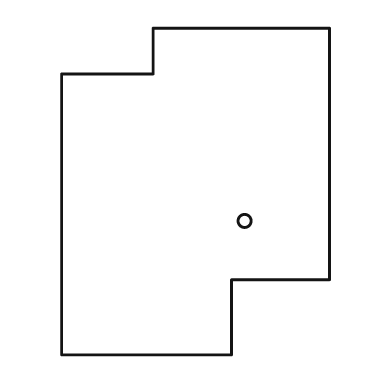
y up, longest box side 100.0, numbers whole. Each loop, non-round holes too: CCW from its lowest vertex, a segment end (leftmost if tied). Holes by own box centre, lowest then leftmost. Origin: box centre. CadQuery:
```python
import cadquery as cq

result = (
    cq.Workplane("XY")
    .moveTo(-41.0, -50.0)
    .lineTo(11.0, -50.0)
    .lineTo(11.0, -27.0)
    .lineTo(41.0, -27.0)
    .lineTo(41.0, 50.0)
    .lineTo(-13.0, 50.0)
    .lineTo(-13.0, 36.0)
    .lineTo(-41.0, 36.0)
    .close()
    .moveTo(15.0, -9.0)
    .circle(2.0)
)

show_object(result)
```